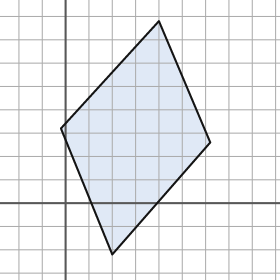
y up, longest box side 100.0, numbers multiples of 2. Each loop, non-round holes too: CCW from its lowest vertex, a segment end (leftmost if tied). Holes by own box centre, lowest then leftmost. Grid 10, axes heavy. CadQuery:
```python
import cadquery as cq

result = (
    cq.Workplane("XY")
    .moveTo(20.0, -22.0)
    .lineTo(62.0, 26.0)
    .lineTo(40.0, 78.0)
    .lineTo(-2.0, 32.0)
    .close()
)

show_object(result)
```